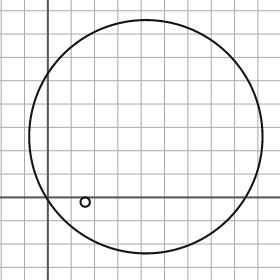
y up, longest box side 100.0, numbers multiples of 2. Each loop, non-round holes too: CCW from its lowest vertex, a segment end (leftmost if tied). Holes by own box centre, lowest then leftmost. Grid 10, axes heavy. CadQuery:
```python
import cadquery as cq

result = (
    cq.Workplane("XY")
    .moveTo(42.0, 26.0)
    .circle(50.0)
    .moveTo(16.0, -2.0)
    .circle(2.0)
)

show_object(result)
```